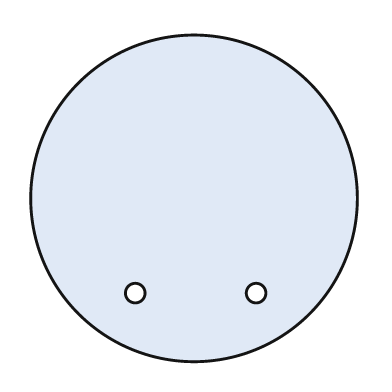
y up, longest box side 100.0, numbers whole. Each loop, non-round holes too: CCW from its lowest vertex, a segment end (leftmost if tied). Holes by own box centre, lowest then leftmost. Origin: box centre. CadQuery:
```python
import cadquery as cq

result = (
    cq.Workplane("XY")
    .moveTo(0.0, 0.0)
    .circle(50.0)
    .moveTo(-18.0, -29.0)
    .circle(3.0)
    .moveTo(19.0, -29.0)
    .circle(3.0)
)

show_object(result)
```